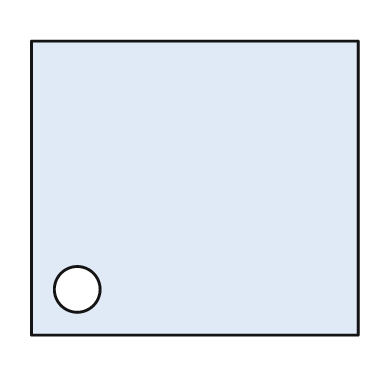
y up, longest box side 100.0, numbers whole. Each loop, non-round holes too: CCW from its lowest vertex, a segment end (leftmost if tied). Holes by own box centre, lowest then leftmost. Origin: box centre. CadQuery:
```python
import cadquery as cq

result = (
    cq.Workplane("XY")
    .moveTo(-50.0, -45.0)
    .lineTo(50.0, -45.0)
    .lineTo(50.0, 45.0)
    .lineTo(-50.0, 45.0)
    .close()
    .moveTo(-36.0, -31.0)
    .circle(7.0)
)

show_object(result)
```